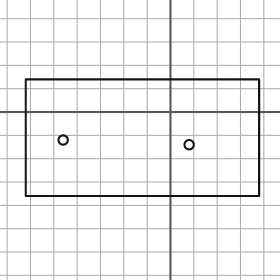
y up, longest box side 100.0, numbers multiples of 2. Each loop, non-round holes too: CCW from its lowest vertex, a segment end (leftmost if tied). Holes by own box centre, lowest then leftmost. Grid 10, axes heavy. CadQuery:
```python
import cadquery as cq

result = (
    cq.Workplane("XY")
    .moveTo(-62.0, -36.0)
    .lineTo(38.0, -36.0)
    .lineTo(38.0, 14.0)
    .lineTo(-62.0, 14.0)
    .close()
    .moveTo(8.0, -14.0)
    .circle(2.0)
    .moveTo(-46.0, -12.0)
    .circle(2.0)
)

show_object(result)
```